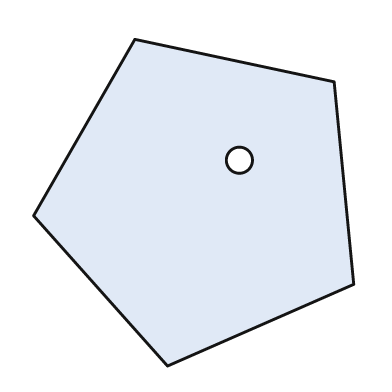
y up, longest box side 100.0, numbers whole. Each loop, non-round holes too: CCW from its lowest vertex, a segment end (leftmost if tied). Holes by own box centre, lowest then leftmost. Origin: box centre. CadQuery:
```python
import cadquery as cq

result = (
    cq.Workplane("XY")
    .moveTo(-8.0, -50.0)
    .lineTo(49.0, -25.0)
    .lineTo(43.0, 37.0)
    .lineTo(-18.0, 50.0)
    .lineTo(-49.0, -4.0)
    .close()
    .moveTo(14.0, 13.0)
    .circle(4.0)
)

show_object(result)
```